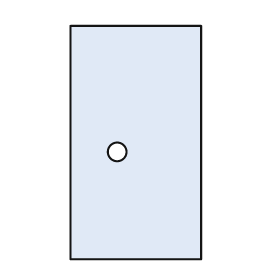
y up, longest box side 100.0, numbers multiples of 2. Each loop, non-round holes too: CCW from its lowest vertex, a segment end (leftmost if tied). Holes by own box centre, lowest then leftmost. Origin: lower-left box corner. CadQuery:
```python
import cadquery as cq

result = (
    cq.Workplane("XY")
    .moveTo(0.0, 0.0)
    .lineTo(56.0, 0.0)
    .lineTo(56.0, 100.0)
    .lineTo(0.0, 100.0)
    .close()
    .moveTo(20.0, 46.0)
    .circle(4.0)
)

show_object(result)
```